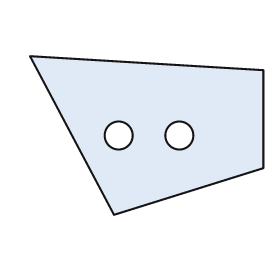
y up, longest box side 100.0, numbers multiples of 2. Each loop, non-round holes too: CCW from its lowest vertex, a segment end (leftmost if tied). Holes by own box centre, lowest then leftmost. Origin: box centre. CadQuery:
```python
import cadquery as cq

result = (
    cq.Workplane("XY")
    .moveTo(-14.0, -34.0)
    .lineTo(50.0, -14.0)
    .lineTo(50.0, 28.0)
    .lineTo(-50.0, 34.0)
    .close()
    .moveTo(-12.0, 0.0)
    .circle(6.0)
    .moveTo(14.0, 0.0)
    .circle(6.0)
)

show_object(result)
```